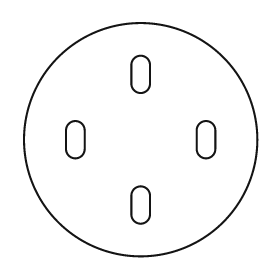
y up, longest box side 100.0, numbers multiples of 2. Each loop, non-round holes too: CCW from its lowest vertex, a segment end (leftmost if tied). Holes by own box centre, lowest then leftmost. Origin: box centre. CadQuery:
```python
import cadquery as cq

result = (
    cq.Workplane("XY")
    .moveTo(0.0, 0.0)
    .circle(50.0)
    .moveTo(-4.0, -32.0)
    .threePointArc((0.0, -36.0), (4.0, -32.0))
    .lineTo(4.0, -24.0)
    .threePointArc((0.0, -20.0), (-4.0, -24.0))
    .close()
    .moveTo(-32.0, -4.0)
    .threePointArc((-28.0, -8.0), (-24.0, -4.0))
    .lineTo(-24.0, 4.0)
    .threePointArc((-28.0, 8.0), (-32.0, 4.0))
    .close()
    .moveTo(24.0, -4.0)
    .threePointArc((28.0, -8.0), (32.0, -4.0))
    .lineTo(32.0, 4.0)
    .threePointArc((28.0, 8.0), (24.0, 4.0))
    .close()
    .moveTo(-4.0, 24.0)
    .threePointArc((0.0, 20.0), (4.0, 24.0))
    .lineTo(4.0, 32.0)
    .threePointArc((0.0, 36.0), (-4.0, 32.0))
    .close()
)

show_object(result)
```